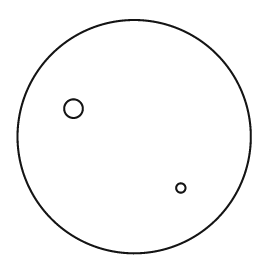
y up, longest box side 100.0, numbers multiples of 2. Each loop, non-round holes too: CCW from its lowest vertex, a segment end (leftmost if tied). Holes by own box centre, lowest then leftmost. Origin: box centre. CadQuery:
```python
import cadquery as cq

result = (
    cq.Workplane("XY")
    .moveTo(0.0, 0.0)
    .circle(50.0)
    .moveTo(20.0, -22.0)
    .circle(2.0)
    .moveTo(-26.0, 12.0)
    .circle(4.0)
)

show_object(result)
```